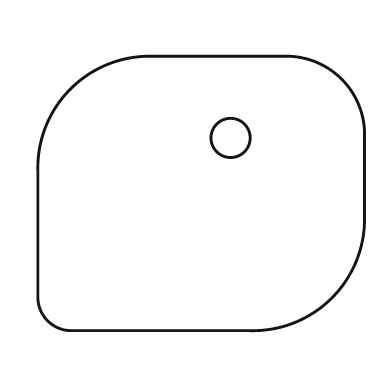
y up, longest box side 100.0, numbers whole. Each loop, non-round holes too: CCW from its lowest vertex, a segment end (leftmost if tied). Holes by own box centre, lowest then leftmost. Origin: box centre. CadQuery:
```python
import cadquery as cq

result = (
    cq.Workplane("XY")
    .moveTo(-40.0, -42.0)
    .lineTo(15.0, -42.0)
    .threePointArc((40.0, -32.0), (50.0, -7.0))
    .lineTo(50.0, 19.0)
    .threePointArc((43.0, 35.0), (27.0, 42.0))
    .lineTo(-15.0, 42.0)
    .threePointArc((-40.0, 32.0), (-50.0, 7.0))
    .lineTo(-50.0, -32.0)
    .threePointArc((-47.0, -39.0), (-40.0, -42.0))
    .close()
    .moveTo(9.0, 17.0)
    .circle(6.0)
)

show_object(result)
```